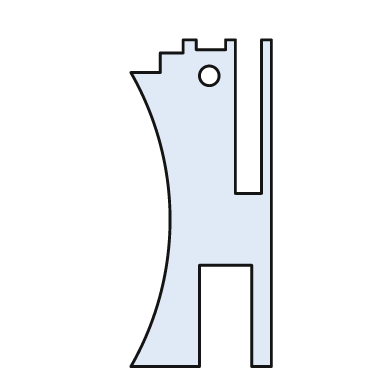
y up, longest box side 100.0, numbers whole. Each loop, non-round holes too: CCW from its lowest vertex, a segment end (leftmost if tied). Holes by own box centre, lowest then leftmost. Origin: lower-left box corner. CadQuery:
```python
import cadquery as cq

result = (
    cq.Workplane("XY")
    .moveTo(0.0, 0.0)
    .lineTo(21.0, 0.0)
    .lineTo(21.0, 31.0)
    .lineTo(37.0, 31.0)
    .lineTo(37.0, 0.0)
    .lineTo(43.0, 0.0)
    .lineTo(43.0, 100.0)
    .lineTo(40.0, 100.0)
    .lineTo(40.0, 53.0)
    .lineTo(32.0, 53.0)
    .lineTo(32.0, 100.0)
    .lineTo(29.0, 100.0)
    .lineTo(29.0, 97.0)
    .lineTo(20.0, 97.0)
    .lineTo(20.0, 100.0)
    .lineTo(16.0, 100.0)
    .lineTo(16.0, 96.0)
    .lineTo(9.0, 96.0)
    .lineTo(9.0, 90.0)
    .lineTo(0.0, 90.0)
    .threePointArc((12.0, 45.0), (0.0, 0.0))
    .close()
    .moveTo(24.0, 89.0)
    .circle(3.0)
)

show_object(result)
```